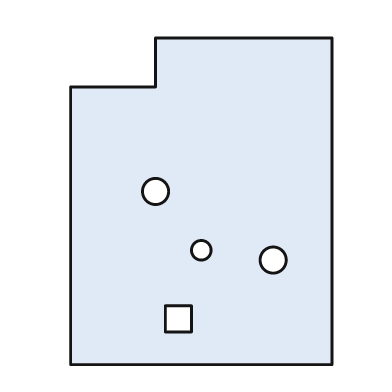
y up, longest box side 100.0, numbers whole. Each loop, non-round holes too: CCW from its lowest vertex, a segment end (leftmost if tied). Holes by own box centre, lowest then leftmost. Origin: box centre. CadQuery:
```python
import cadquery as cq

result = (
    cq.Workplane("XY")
    .moveTo(-40.0, -50.0)
    .lineTo(40.0, -50.0)
    .lineTo(40.0, 50.0)
    .lineTo(-14.0, 50.0)
    .lineTo(-14.0, 35.0)
    .lineTo(-40.0, 35.0)
    .close()
    .moveTo(-11.0, -40.0)
    .lineTo(-3.0, -40.0)
    .lineTo(-3.0, -32.0)
    .lineTo(-11.0, -32.0)
    .close()
    .moveTo(22.0, -18.0)
    .circle(4.0)
    .moveTo(0.0, -15.0)
    .circle(3.0)
    .moveTo(-14.0, 3.0)
    .circle(4.0)
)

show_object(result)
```